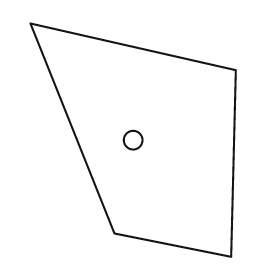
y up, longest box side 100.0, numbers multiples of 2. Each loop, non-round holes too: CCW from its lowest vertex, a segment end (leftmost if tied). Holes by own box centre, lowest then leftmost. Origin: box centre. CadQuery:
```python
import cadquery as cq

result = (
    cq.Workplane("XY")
    .moveTo(42.0, -50.0)
    .lineTo(44.0, 30.0)
    .lineTo(-44.0, 50.0)
    .lineTo(-8.0, -40.0)
    .close()
    .moveTo(0.0, 0.0)
    .circle(4.0)
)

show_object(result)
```